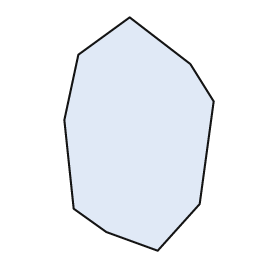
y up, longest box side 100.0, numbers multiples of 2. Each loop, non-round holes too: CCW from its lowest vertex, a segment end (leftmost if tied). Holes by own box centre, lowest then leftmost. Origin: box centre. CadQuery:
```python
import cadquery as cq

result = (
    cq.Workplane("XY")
    .moveTo(8.0, -50.0)
    .lineTo(26.0, -30.0)
    .lineTo(32.0, 14.0)
    .lineTo(22.0, 30.0)
    .lineTo(-4.0, 50.0)
    .lineTo(-26.0, 34.0)
    .lineTo(-32.0, 6.0)
    .lineTo(-28.0, -32.0)
    .lineTo(-14.0, -42.0)
    .close()
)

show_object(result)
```